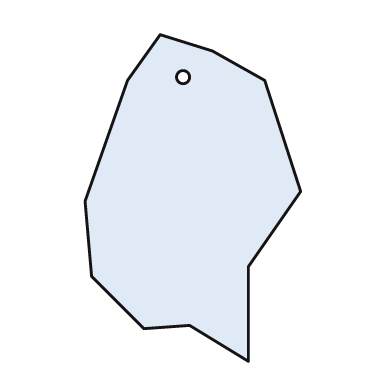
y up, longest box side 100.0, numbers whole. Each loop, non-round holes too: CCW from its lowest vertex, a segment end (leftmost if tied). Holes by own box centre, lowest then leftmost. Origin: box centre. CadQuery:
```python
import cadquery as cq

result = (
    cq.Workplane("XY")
    .moveTo(17.0, -50.0)
    .lineTo(17.0, -21.0)
    .lineTo(33.0, 2.0)
    .lineTo(22.0, 36.0)
    .lineTo(6.0, 45.0)
    .lineTo(-10.0, 50.0)
    .lineTo(-20.0, 36.0)
    .lineTo(-33.0, -1.0)
    .lineTo(-31.0, -24.0)
    .lineTo(-15.0, -40.0)
    .lineTo(-1.0, -39.0)
    .close()
    .moveTo(-3.0, 37.0)
    .circle(2.0)
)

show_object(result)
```